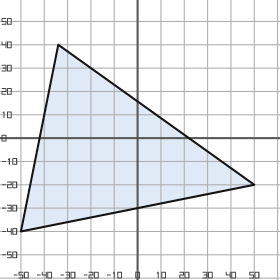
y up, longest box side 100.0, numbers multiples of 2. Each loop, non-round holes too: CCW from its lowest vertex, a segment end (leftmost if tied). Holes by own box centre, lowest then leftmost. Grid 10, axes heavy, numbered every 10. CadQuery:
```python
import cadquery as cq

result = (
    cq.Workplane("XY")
    .moveTo(-50.0, -40.0)
    .lineTo(50.0, -20.0)
    .lineTo(-34.0, 40.0)
    .close()
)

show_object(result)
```